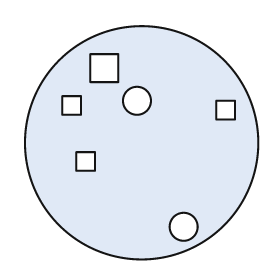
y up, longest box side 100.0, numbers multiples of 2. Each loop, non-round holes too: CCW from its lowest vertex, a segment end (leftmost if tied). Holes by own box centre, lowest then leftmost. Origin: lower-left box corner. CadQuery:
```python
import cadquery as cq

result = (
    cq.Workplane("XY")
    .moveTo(50.0, 50.0)
    .circle(50.0)
    .moveTo(68.0, 14.0)
    .circle(6.0)
    .moveTo(22.0, 38.0)
    .lineTo(30.0, 38.0)
    .lineTo(30.0, 46.0)
    .lineTo(22.0, 46.0)
    .close()
    .moveTo(82.0, 60.0)
    .lineTo(90.0, 60.0)
    .lineTo(90.0, 68.0)
    .lineTo(82.0, 68.0)
    .close()
    .moveTo(16.0, 62.0)
    .lineTo(24.0, 62.0)
    .lineTo(24.0, 70.0)
    .lineTo(16.0, 70.0)
    .close()
    .moveTo(48.0, 68.0)
    .circle(6.0)
    .moveTo(28.0, 76.0)
    .lineTo(40.0, 76.0)
    .lineTo(40.0, 88.0)
    .lineTo(28.0, 88.0)
    .close()
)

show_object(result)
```